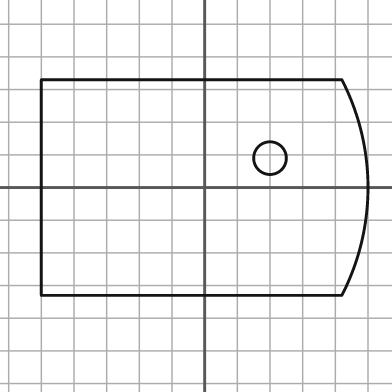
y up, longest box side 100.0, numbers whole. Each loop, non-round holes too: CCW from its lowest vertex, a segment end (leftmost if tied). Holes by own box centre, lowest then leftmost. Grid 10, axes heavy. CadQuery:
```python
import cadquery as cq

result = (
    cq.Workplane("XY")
    .moveTo(-50.0, -33.0)
    .lineTo(42.0, -33.0)
    .threePointArc((50.0, 0.0), (42.0, 33.0))
    .lineTo(-50.0, 33.0)
    .close()
    .moveTo(20.0, 9.0)
    .circle(5.0)
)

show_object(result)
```